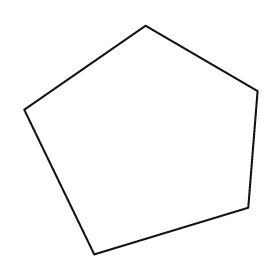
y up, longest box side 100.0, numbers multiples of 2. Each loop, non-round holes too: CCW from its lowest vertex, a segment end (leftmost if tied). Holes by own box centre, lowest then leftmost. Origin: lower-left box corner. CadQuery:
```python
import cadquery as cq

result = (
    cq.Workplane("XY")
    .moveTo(30.0, 0.0)
    .lineTo(96.0, 20.0)
    .lineTo(100.0, 70.0)
    .lineTo(52.0, 98.0)
    .lineTo(0.0, 62.0)
    .close()
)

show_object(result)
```